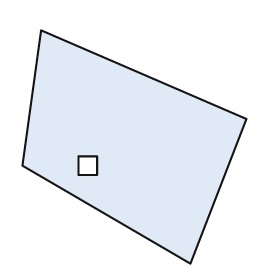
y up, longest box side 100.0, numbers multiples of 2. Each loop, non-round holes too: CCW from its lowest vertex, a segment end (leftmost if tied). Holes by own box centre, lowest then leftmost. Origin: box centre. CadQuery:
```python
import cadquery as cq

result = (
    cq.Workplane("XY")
    .moveTo(24.0, -50.0)
    .lineTo(48.0, 12.0)
    .lineTo(-40.0, 50.0)
    .lineTo(-48.0, -8.0)
    .close()
    .moveTo(-24.0, -12.0)
    .lineTo(-16.0, -12.0)
    .lineTo(-16.0, -4.0)
    .lineTo(-24.0, -4.0)
    .close()
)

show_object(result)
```